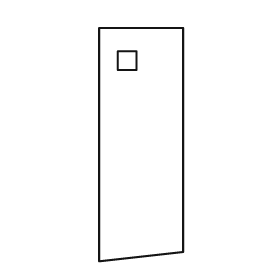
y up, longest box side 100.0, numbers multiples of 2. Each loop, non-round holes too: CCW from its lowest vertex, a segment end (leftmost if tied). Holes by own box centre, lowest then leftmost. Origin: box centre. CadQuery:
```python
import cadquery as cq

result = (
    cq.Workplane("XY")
    .moveTo(-18.0, -50.0)
    .lineTo(18.0, -46.0)
    .lineTo(18.0, 50.0)
    .lineTo(-18.0, 50.0)
    .close()
    .moveTo(-10.0, 32.0)
    .lineTo(-2.0, 32.0)
    .lineTo(-2.0, 40.0)
    .lineTo(-10.0, 40.0)
    .close()
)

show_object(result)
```